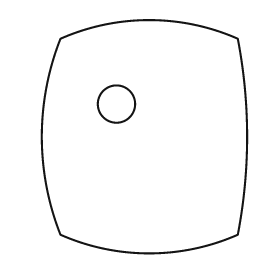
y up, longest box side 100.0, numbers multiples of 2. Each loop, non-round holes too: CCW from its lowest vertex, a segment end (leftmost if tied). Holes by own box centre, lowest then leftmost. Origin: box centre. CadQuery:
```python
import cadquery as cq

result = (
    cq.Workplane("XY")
    .moveTo(-36.0, -42.0)
    .threePointArc((2.0, -50.0), (40.0, -42.0))
    .threePointArc((44.0, 0.0), (40.0, 42.0))
    .threePointArc((2.0, 50.0), (-36.0, 42.0))
    .threePointArc((-44.0, 0.0), (-36.0, -42.0))
    .close()
    .moveTo(-12.0, 14.0)
    .circle(8.0)
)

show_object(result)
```